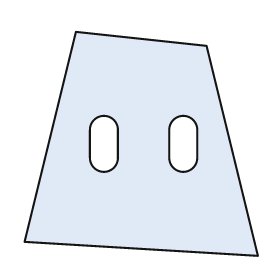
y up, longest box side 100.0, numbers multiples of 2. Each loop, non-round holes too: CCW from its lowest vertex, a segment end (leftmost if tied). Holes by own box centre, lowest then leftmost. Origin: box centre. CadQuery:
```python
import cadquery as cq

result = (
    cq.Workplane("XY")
    .moveTo(50.0, -48.0)
    .lineTo(28.0, 42.0)
    .lineTo(-28.0, 48.0)
    .lineTo(-50.0, -42.0)
    .close()
    .moveTo(-22.0, -6.0)
    .threePointArc((-16.0, -12.0), (-10.0, -6.0))
    .lineTo(-10.0, 6.0)
    .threePointArc((-16.0, 12.0), (-22.0, 6.0))
    .close()
    .moveTo(12.0, -6.0)
    .threePointArc((18.0, -12.0), (24.0, -6.0))
    .lineTo(24.0, 6.0)
    .threePointArc((18.0, 12.0), (12.0, 6.0))
    .close()
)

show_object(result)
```